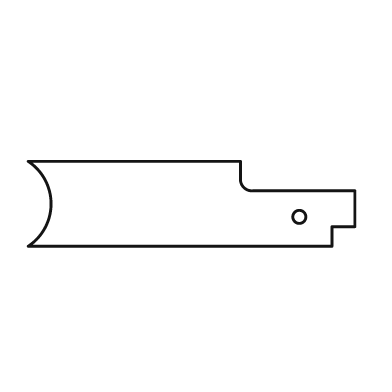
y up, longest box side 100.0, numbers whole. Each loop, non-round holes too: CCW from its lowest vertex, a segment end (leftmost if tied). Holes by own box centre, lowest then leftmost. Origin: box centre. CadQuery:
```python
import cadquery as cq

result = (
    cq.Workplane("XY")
    .moveTo(-50.0, -13.0)
    .lineTo(43.0, -13.0)
    .lineTo(43.0, -7.0)
    .lineTo(50.0, -7.0)
    .lineTo(50.0, 4.0)
    .lineTo(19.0, 4.0)
    .threePointArc((16.0, 5.0), (15.0, 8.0))
    .lineTo(15.0, 13.0)
    .lineTo(-50.0, 13.0)
    .threePointArc((-43.0, 0.0), (-50.0, -13.0))
    .close()
    .moveTo(33.0, -4.0)
    .circle(2.0)
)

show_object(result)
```